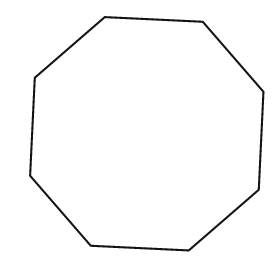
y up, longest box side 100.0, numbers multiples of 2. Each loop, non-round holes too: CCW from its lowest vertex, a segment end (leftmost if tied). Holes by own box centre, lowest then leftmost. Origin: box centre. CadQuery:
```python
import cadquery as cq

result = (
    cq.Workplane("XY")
    .moveTo(18.0, -50.0)
    .lineTo(48.0, -24.0)
    .lineTo(50.0, 18.0)
    .lineTo(24.0, 48.0)
    .lineTo(-18.0, 50.0)
    .lineTo(-48.0, 24.0)
    .lineTo(-50.0, -18.0)
    .lineTo(-24.0, -48.0)
    .close()
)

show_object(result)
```